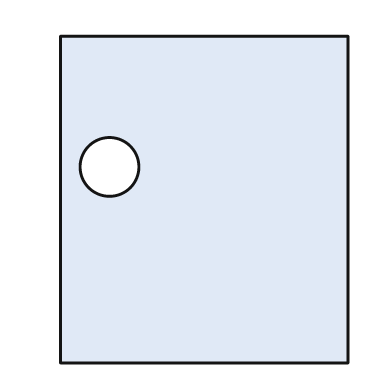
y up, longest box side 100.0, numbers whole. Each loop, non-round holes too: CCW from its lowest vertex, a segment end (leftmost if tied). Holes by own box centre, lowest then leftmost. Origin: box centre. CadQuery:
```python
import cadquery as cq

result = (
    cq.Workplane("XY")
    .moveTo(-44.0, -50.0)
    .lineTo(44.0, -50.0)
    .lineTo(44.0, 50.0)
    .lineTo(-44.0, 50.0)
    .close()
    .moveTo(-29.0, 10.0)
    .circle(9.0)
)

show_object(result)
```